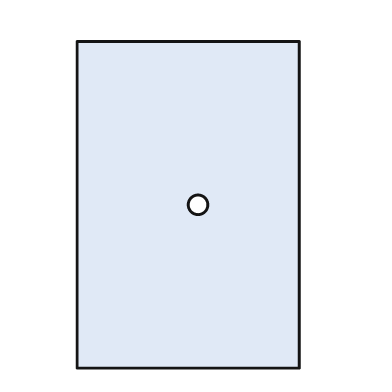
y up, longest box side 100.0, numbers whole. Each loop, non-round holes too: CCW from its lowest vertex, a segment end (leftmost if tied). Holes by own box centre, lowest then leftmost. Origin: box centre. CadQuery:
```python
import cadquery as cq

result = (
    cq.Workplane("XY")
    .moveTo(-34.0, -50.0)
    .lineTo(34.0, -50.0)
    .lineTo(34.0, 50.0)
    .lineTo(-34.0, 50.0)
    .close()
    .moveTo(3.0, 0.0)
    .circle(3.0)
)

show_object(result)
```